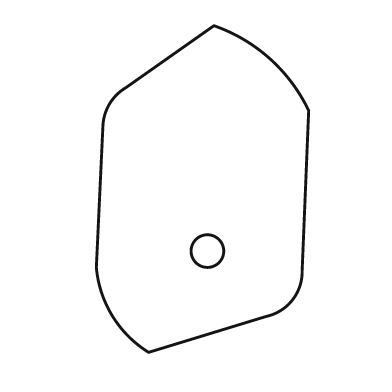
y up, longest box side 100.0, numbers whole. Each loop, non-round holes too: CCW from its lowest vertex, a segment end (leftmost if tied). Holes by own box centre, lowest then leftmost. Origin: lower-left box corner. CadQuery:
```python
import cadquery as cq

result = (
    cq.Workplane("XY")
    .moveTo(16.0, 0.0)
    .lineTo(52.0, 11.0)
    .threePointArc((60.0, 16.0), (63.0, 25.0))
    .lineTo(65.0, 74.0)
    .threePointArc((53.0, 90.0), (36.0, 100.0))
    .lineTo(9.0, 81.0)
    .threePointArc((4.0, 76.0), (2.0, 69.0))
    .lineTo(0.0, 26.0)
    .threePointArc((5.0, 11.0), (16.0, 0.0))
    .close()
    .moveTo(34.0, 31.0)
    .circle(5.0)
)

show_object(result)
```